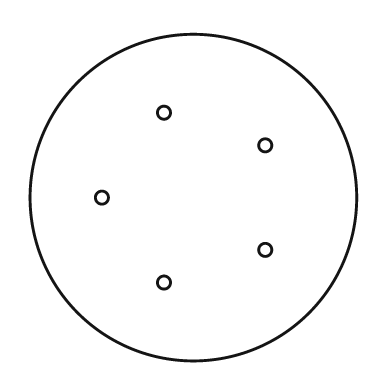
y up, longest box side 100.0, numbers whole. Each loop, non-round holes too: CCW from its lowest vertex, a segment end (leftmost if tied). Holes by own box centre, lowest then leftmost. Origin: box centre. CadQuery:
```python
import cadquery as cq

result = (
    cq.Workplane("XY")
    .moveTo(0.0, 0.0)
    .circle(50.0)
    .moveTo(-9.0, -26.0)
    .circle(2.0)
    .moveTo(22.0, -16.0)
    .circle(2.0)
    .moveTo(-28.0, 0.0)
    .circle(2.0)
    .moveTo(22.0, 16.0)
    .circle(2.0)
    .moveTo(-9.0, 26.0)
    .circle(2.0)
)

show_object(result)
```